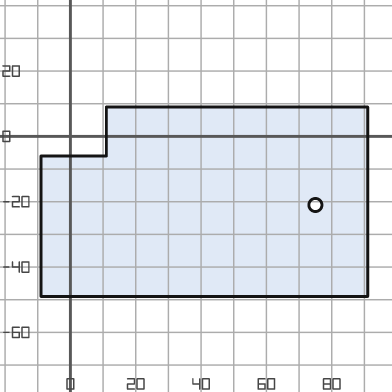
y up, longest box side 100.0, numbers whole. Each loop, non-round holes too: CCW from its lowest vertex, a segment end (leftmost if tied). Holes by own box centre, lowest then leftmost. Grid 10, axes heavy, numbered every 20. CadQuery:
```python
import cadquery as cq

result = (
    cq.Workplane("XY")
    .moveTo(-9.0, -49.0)
    .lineTo(91.0, -49.0)
    .lineTo(91.0, 9.0)
    .lineTo(11.0, 9.0)
    .lineTo(11.0, -6.0)
    .lineTo(-9.0, -6.0)
    .close()
    .moveTo(75.0, -21.0)
    .circle(2.0)
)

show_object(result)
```